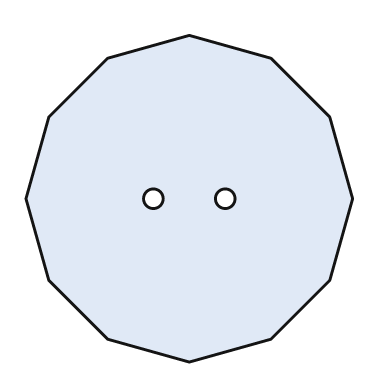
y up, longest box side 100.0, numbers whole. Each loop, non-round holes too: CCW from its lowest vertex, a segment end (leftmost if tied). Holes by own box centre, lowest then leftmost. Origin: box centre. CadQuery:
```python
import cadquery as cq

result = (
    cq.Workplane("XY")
    .moveTo(0.0, -50.0)
    .lineTo(25.0, -43.0)
    .lineTo(43.0, -25.0)
    .lineTo(50.0, 0.0)
    .lineTo(43.0, 25.0)
    .lineTo(25.0, 43.0)
    .lineTo(0.0, 50.0)
    .lineTo(-25.0, 43.0)
    .lineTo(-43.0, 25.0)
    .lineTo(-50.0, 0.0)
    .lineTo(-43.0, -25.0)
    .lineTo(-25.0, -43.0)
    .close()
    .moveTo(-11.0, 0.0)
    .circle(3.0)
    .moveTo(11.0, 0.0)
    .circle(3.0)
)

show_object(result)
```